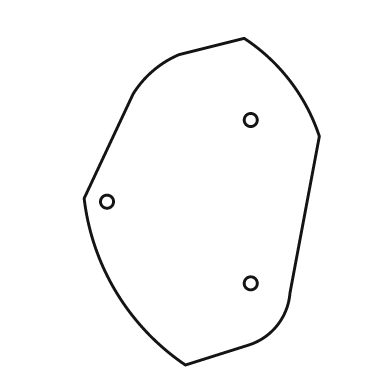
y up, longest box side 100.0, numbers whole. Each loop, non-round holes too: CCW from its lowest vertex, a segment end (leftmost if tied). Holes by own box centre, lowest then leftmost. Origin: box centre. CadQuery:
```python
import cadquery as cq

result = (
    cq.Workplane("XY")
    .moveTo(-5.0, -50.0)
    .lineTo(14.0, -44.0)
    .threePointArc((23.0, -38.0), (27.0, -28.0))
    .lineTo(36.0, 20.0)
    .threePointArc((27.0, 37.0), (13.0, 50.0))
    .lineTo(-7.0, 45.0)
    .threePointArc((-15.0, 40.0), (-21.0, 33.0))
    .lineTo(-36.0, 1.0)
    .threePointArc((-26.0, -28.0), (-5.0, -50.0))
    .close()
    .moveTo(15.0, -25.0)
    .circle(2.0)
    .moveTo(-29.0, 0.0)
    .circle(2.0)
    .moveTo(15.0, 25.0)
    .circle(2.0)
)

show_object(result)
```